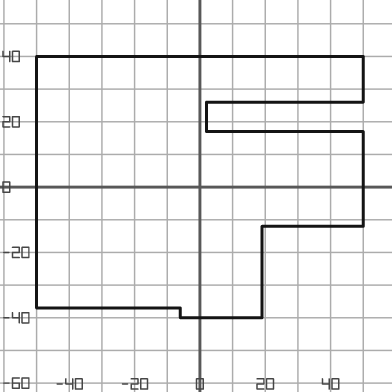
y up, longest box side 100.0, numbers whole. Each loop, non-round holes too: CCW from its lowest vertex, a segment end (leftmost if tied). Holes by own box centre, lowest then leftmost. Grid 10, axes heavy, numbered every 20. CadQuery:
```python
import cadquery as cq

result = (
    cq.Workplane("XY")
    .moveTo(-6.0, -40.0)
    .lineTo(19.0, -40.0)
    .lineTo(19.0, -12.0)
    .lineTo(50.0, -12.0)
    .lineTo(50.0, 17.0)
    .lineTo(2.0, 17.0)
    .lineTo(2.0, 26.0)
    .lineTo(50.0, 26.0)
    .lineTo(50.0, 40.0)
    .lineTo(-50.0, 40.0)
    .lineTo(-50.0, -37.0)
    .lineTo(-6.0, -37.0)
    .close()
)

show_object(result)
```